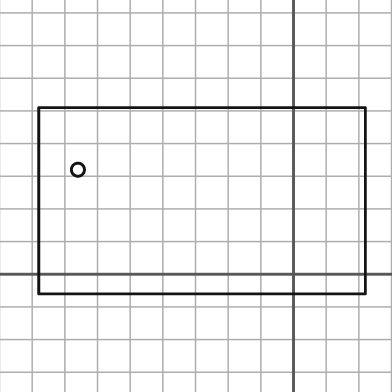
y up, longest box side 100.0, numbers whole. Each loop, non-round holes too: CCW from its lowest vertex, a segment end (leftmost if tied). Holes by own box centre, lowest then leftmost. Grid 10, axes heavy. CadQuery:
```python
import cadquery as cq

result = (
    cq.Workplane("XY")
    .moveTo(-78.0, -6.0)
    .lineTo(22.0, -6.0)
    .lineTo(22.0, 51.0)
    .lineTo(-78.0, 51.0)
    .close()
    .moveTo(-66.0, 32.0)
    .circle(2.0)
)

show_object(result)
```